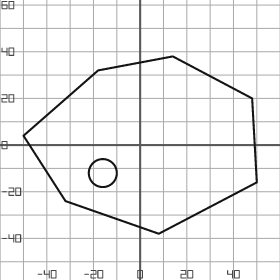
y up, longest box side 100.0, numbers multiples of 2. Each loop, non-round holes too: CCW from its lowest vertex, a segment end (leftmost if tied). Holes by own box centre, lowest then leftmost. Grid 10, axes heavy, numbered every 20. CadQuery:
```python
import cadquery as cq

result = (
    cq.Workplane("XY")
    .moveTo(8.0, -38.0)
    .lineTo(50.0, -16.0)
    .lineTo(48.0, 20.0)
    .lineTo(14.0, 38.0)
    .lineTo(-18.0, 32.0)
    .lineTo(-50.0, 4.0)
    .lineTo(-32.0, -24.0)
    .close()
    .moveTo(-16.0, -12.0)
    .circle(6.0)
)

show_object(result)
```